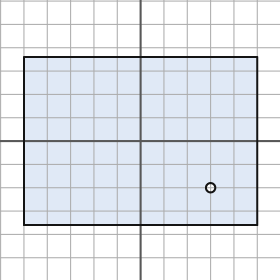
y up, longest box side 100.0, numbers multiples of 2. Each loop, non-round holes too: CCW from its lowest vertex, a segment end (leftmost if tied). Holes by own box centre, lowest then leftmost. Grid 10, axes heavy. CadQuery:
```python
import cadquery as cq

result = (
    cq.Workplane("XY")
    .moveTo(-50.0, -36.0)
    .lineTo(50.0, -36.0)
    .lineTo(50.0, 36.0)
    .lineTo(-50.0, 36.0)
    .close()
    .moveTo(30.0, -20.0)
    .circle(2.0)
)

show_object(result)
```